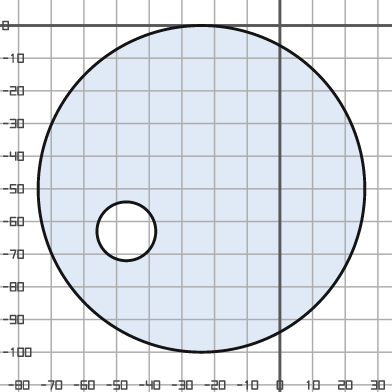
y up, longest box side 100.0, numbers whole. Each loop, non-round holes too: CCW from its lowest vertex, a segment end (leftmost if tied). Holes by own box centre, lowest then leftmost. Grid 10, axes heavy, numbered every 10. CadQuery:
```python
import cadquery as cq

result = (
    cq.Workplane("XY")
    .moveTo(-24.0, -50.0)
    .circle(50.0)
    .moveTo(-47.0, -63.0)
    .circle(9.0)
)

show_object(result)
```